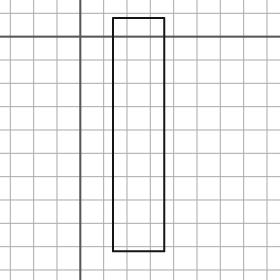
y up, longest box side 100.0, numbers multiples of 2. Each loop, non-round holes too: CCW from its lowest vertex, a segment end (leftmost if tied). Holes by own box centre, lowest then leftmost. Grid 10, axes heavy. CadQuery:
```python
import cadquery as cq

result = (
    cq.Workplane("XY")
    .moveTo(14.0, -92.0)
    .lineTo(36.0, -92.0)
    .lineTo(36.0, 8.0)
    .lineTo(14.0, 8.0)
    .close()
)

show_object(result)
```